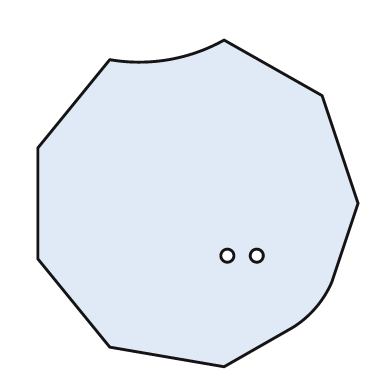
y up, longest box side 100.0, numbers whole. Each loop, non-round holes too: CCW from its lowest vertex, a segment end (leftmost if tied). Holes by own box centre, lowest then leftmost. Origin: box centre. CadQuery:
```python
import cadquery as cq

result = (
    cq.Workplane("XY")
    .moveTo(8.0, -50.0)
    .lineTo(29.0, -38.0)
    .threePointArc((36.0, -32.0), (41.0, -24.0))
    .lineTo(49.0, 0.0)
    .lineTo(38.0, 33.0)
    .lineTo(8.0, 50.0)
    .threePointArc((-9.0, 44.0), (-27.0, 44.0))
    .lineTo(-49.0, 17.0)
    .lineTo(-49.0, -17.0)
    .lineTo(-27.0, -44.0)
    .close()
    .moveTo(9.0, -16.0)
    .circle(2.0)
    .moveTo(18.0, -16.0)
    .circle(2.0)
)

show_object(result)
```